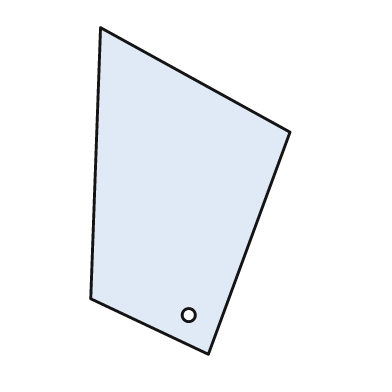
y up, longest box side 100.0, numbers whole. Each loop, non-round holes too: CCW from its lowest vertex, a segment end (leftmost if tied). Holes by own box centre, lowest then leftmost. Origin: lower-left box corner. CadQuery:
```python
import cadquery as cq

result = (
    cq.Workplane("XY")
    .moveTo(36.0, 0.0)
    .lineTo(61.0, 68.0)
    .lineTo(3.0, 100.0)
    .lineTo(0.0, 17.0)
    .close()
    .moveTo(30.0, 12.0)
    .circle(2.0)
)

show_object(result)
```